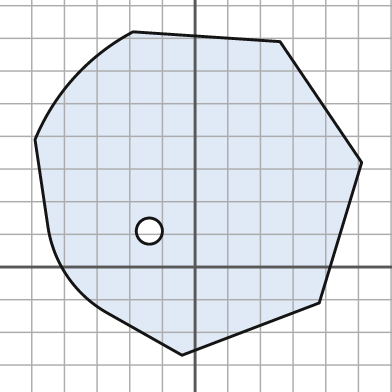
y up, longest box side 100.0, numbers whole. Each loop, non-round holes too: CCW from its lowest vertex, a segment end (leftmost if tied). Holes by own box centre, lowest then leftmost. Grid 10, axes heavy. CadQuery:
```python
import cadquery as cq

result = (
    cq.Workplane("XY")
    .moveTo(-4.0, -27.0)
    .lineTo(38.0, -11.0)
    .lineTo(51.0, 32.0)
    .lineTo(26.0, 69.0)
    .lineTo(-19.0, 72.0)
    .threePointArc((-37.0, 58.0), (-49.0, 39.0))
    .lineTo(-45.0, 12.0)
    .threePointArc((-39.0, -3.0), (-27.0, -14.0))
    .close()
    .moveTo(-14.0, 11.0)
    .circle(4.0)
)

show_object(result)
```